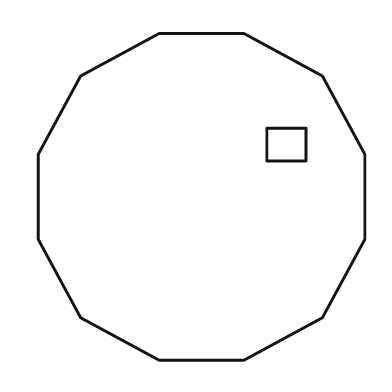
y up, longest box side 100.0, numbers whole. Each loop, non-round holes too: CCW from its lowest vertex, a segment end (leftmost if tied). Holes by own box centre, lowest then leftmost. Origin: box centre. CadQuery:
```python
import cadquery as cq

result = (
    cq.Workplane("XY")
    .moveTo(-13.0, -50.0)
    .lineTo(13.0, -50.0)
    .lineTo(37.0, -37.0)
    .lineTo(50.0, -13.0)
    .lineTo(50.0, 13.0)
    .lineTo(37.0, 37.0)
    .lineTo(13.0, 50.0)
    .lineTo(-13.0, 50.0)
    .lineTo(-37.0, 37.0)
    .lineTo(-50.0, 13.0)
    .lineTo(-50.0, -13.0)
    .lineTo(-37.0, -37.0)
    .close()
    .moveTo(20.0, 11.0)
    .lineTo(32.0, 11.0)
    .lineTo(32.0, 21.0)
    .lineTo(20.0, 21.0)
    .close()
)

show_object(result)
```